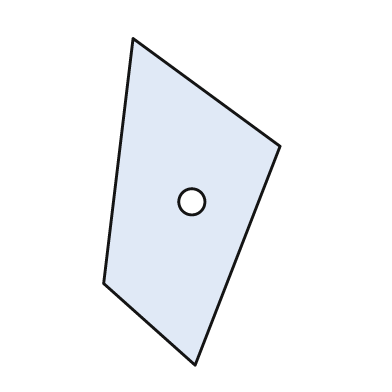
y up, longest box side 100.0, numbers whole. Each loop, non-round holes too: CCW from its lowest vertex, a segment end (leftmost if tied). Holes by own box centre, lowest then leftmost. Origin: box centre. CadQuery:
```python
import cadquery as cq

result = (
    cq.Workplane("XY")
    .moveTo(1.0, -50.0)
    .lineTo(27.0, 17.0)
    .lineTo(-18.0, 50.0)
    .lineTo(-27.0, -25.0)
    .close()
    .moveTo(0.0, 0.0)
    .circle(4.0)
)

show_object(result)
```